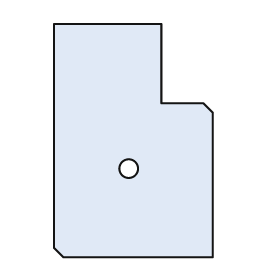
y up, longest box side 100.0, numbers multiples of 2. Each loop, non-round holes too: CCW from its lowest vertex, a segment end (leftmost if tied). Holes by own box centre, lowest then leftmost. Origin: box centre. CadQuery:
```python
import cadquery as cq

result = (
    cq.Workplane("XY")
    .moveTo(-30.0, -50.0)
    .lineTo(34.0, -50.0)
    .lineTo(34.0, 12.0)
    .lineTo(30.0, 16.0)
    .lineTo(12.0, 16.0)
    .lineTo(12.0, 50.0)
    .lineTo(-34.0, 50.0)
    .lineTo(-34.0, -46.0)
    .close()
    .moveTo(-2.0, -12.0)
    .circle(4.0)
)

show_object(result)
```